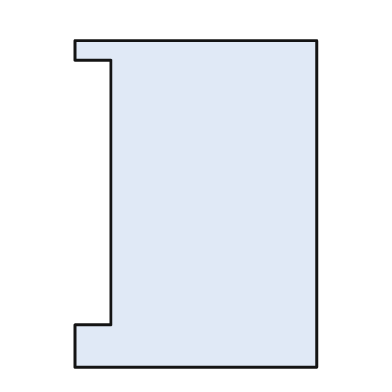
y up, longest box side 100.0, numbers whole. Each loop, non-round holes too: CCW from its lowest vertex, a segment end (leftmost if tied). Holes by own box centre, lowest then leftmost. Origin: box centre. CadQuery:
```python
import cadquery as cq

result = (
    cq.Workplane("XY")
    .moveTo(-37.0, -50.0)
    .lineTo(37.0, -50.0)
    .lineTo(37.0, 50.0)
    .lineTo(-37.0, 50.0)
    .lineTo(-37.0, 44.0)
    .lineTo(-26.0, 44.0)
    .lineTo(-26.0, -37.0)
    .lineTo(-37.0, -37.0)
    .close()
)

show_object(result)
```